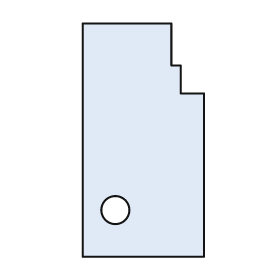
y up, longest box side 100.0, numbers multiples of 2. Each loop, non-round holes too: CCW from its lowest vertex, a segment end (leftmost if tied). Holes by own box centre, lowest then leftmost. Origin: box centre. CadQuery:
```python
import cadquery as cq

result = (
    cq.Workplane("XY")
    .moveTo(-26.0, -50.0)
    .lineTo(26.0, -50.0)
    .lineTo(26.0, 20.0)
    .lineTo(16.0, 20.0)
    .lineTo(16.0, 32.0)
    .lineTo(12.0, 32.0)
    .lineTo(12.0, 50.0)
    .lineTo(-26.0, 50.0)
    .close()
    .moveTo(-12.0, -30.0)
    .circle(6.0)
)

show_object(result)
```